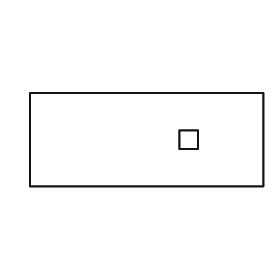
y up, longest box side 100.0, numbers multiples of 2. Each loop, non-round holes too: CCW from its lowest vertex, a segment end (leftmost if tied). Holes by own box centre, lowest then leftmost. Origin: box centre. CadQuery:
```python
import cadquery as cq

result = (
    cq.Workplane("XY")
    .moveTo(-50.0, -20.0)
    .lineTo(50.0, -20.0)
    .lineTo(50.0, 20.0)
    .lineTo(-50.0, 20.0)
    .close()
    .moveTo(14.0, -4.0)
    .lineTo(22.0, -4.0)
    .lineTo(22.0, 4.0)
    .lineTo(14.0, 4.0)
    .close()
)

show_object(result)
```